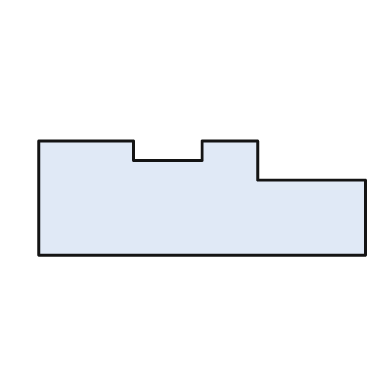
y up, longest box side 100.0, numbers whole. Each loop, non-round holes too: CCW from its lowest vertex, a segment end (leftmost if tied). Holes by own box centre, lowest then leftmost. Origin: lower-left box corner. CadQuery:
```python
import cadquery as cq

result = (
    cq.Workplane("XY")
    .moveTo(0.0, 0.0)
    .lineTo(100.0, 0.0)
    .lineTo(100.0, 23.0)
    .lineTo(67.0, 23.0)
    .lineTo(67.0, 35.0)
    .lineTo(50.0, 35.0)
    .lineTo(50.0, 29.0)
    .lineTo(29.0, 29.0)
    .lineTo(29.0, 35.0)
    .lineTo(0.0, 35.0)
    .close()
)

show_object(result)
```